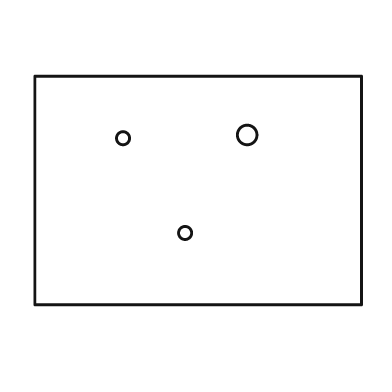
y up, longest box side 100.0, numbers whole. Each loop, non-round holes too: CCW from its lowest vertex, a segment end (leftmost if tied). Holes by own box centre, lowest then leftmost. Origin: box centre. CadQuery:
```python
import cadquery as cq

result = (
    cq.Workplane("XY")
    .moveTo(-50.0, -35.0)
    .lineTo(50.0, -35.0)
    .lineTo(50.0, 35.0)
    .lineTo(-50.0, 35.0)
    .close()
    .moveTo(-4.0, -13.0)
    .circle(2.0)
    .moveTo(-23.0, 16.0)
    .circle(2.0)
    .moveTo(15.0, 17.0)
    .circle(3.0)
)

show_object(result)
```